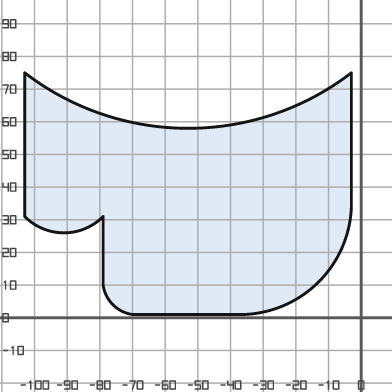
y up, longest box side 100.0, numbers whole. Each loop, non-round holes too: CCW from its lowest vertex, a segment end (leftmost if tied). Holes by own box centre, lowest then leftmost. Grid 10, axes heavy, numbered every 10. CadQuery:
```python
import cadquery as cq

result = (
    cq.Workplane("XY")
    .moveTo(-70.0, 1.0)
    .lineTo(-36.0, 1.0)
    .threePointArc((-13.0, 11.0), (-3.0, 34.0))
    .lineTo(-3.0, 75.0)
    .threePointArc((-53.0, 58.0), (-103.0, 75.0))
    .lineTo(-103.0, 31.0)
    .threePointArc((-91.0, 26.0), (-79.0, 31.0))
    .lineTo(-79.0, 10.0)
    .threePointArc((-76.0, 4.0), (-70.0, 1.0))
    .close()
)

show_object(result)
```